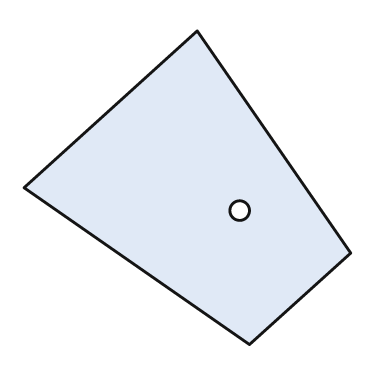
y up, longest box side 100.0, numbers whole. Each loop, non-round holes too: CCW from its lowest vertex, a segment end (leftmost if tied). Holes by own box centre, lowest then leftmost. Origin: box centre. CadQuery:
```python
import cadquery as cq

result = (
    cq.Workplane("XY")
    .moveTo(19.0, -48.0)
    .lineTo(50.0, -20.0)
    .lineTo(3.0, 48.0)
    .lineTo(-50.0, 0.0)
    .close()
    .moveTo(16.0, -7.0)
    .circle(3.0)
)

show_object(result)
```